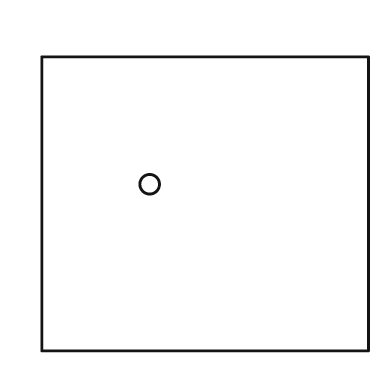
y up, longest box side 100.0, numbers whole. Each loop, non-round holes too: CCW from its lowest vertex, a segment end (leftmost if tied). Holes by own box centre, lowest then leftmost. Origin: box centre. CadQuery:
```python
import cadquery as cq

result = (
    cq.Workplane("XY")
    .moveTo(-50.0, -45.0)
    .lineTo(50.0, -45.0)
    .lineTo(50.0, 45.0)
    .lineTo(-50.0, 45.0)
    .close()
    .moveTo(-17.0, 6.0)
    .circle(3.0)
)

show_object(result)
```